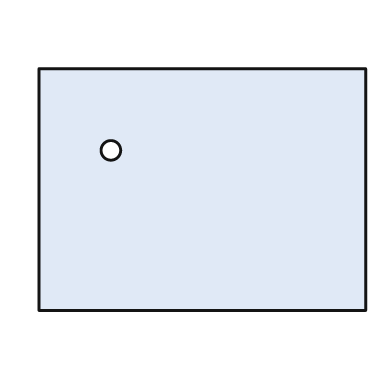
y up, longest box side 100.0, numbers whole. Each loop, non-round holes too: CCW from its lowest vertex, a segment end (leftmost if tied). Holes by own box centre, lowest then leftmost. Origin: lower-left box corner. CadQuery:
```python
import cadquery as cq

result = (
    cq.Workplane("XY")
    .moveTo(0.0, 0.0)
    .lineTo(100.0, 0.0)
    .lineTo(100.0, 74.0)
    .lineTo(0.0, 74.0)
    .close()
    .moveTo(22.0, 49.0)
    .circle(3.0)
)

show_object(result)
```